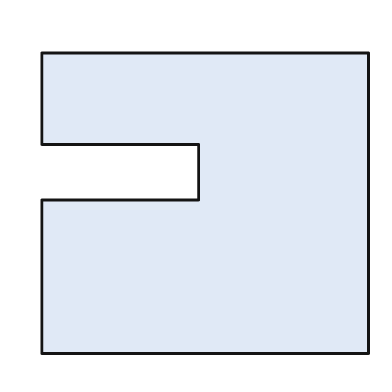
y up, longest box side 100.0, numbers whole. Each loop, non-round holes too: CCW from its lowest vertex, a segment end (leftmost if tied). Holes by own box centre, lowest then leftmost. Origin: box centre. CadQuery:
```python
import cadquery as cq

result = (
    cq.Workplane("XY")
    .moveTo(-50.0, -46.0)
    .lineTo(50.0, -46.0)
    .lineTo(50.0, 46.0)
    .lineTo(-50.0, 46.0)
    .lineTo(-50.0, 18.0)
    .lineTo(-2.0, 18.0)
    .lineTo(-2.0, 1.0)
    .lineTo(-50.0, 1.0)
    .close()
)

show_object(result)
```